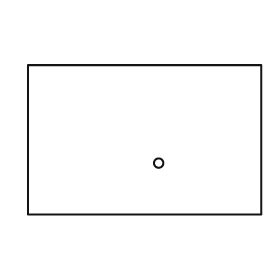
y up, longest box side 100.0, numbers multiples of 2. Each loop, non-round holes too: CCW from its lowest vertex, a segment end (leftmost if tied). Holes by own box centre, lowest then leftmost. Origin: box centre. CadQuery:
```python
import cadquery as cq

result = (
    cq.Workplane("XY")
    .moveTo(-50.0, -32.0)
    .lineTo(50.0, -32.0)
    .lineTo(50.0, 32.0)
    .lineTo(-50.0, 32.0)
    .close()
    .moveTo(6.0, -10.0)
    .circle(2.0)
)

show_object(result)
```